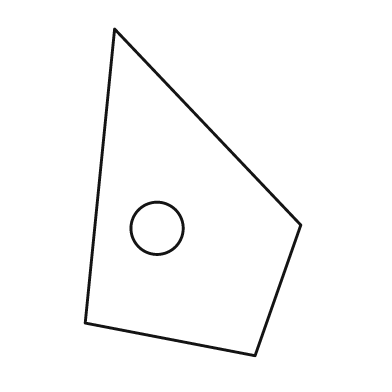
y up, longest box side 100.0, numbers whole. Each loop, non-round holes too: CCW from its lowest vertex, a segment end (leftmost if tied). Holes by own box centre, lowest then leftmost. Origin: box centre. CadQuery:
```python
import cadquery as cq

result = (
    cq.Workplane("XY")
    .moveTo(19.0, -50.0)
    .lineTo(33.0, -10.0)
    .lineTo(-24.0, 50.0)
    .lineTo(-33.0, -40.0)
    .close()
    .moveTo(-11.0, -11.0)
    .circle(8.0)
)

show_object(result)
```